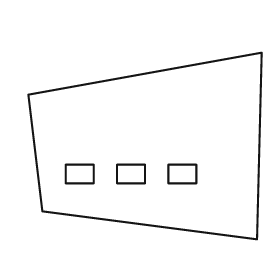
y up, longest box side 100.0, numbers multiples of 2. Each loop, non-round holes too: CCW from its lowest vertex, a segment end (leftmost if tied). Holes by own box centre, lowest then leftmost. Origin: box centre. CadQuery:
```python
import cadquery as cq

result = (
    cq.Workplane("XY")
    .moveTo(48.0, -40.0)
    .lineTo(50.0, 40.0)
    .lineTo(-50.0, 22.0)
    .lineTo(-44.0, -28.0)
    .close()
    .moveTo(-34.0, -16.0)
    .lineTo(-22.0, -16.0)
    .lineTo(-22.0, -8.0)
    .lineTo(-34.0, -8.0)
    .close()
    .moveTo(-12.0, -16.0)
    .lineTo(0.0, -16.0)
    .lineTo(0.0, -8.0)
    .lineTo(-12.0, -8.0)
    .close()
    .moveTo(10.0, -16.0)
    .lineTo(22.0, -16.0)
    .lineTo(22.0, -8.0)
    .lineTo(10.0, -8.0)
    .close()
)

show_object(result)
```